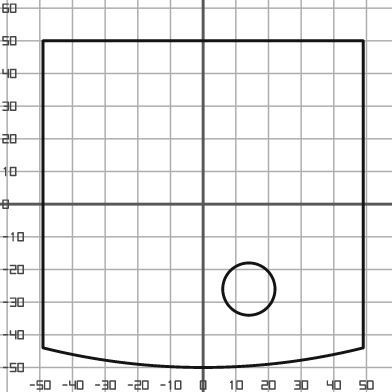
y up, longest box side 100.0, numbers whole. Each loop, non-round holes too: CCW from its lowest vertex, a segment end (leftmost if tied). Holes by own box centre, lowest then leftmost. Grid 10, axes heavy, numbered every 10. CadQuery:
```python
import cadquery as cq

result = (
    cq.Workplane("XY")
    .moveTo(-49.0, -44.0)
    .threePointArc((0.0, -50.0), (49.0, -44.0))
    .lineTo(49.0, 50.0)
    .lineTo(-49.0, 50.0)
    .close()
    .moveTo(14.0, -26.0)
    .circle(8.0)
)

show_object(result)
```